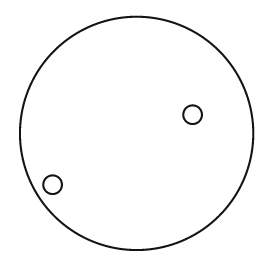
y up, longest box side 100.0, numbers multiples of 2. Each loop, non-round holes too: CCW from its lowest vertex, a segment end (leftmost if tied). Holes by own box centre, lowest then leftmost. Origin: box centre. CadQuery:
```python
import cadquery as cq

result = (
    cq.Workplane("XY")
    .moveTo(0.0, 0.0)
    .circle(50.0)
    .moveTo(-36.0, -22.0)
    .circle(4.0)
    .moveTo(24.0, 8.0)
    .circle(4.0)
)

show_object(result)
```